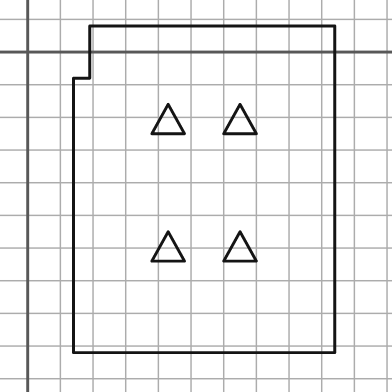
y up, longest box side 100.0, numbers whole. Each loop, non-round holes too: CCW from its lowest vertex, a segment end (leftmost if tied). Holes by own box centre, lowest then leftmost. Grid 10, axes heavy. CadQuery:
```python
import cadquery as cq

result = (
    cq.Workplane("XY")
    .moveTo(14.0, -92.0)
    .lineTo(94.0, -92.0)
    .lineTo(94.0, 8.0)
    .lineTo(19.0, 8.0)
    .lineTo(19.0, -8.0)
    .lineTo(14.0, -8.0)
    .close()
    .moveTo(38.0, -64.0)
    .lineTo(48.0, -64.0)
    .lineTo(43.0, -55.0)
    .close()
    .moveTo(60.0, -64.0)
    .lineTo(70.0, -64.0)
    .lineTo(65.0, -55.0)
    .close()
    .moveTo(38.0, -25.0)
    .lineTo(48.0, -25.0)
    .lineTo(43.0, -16.0)
    .close()
    .moveTo(60.0, -25.0)
    .lineTo(70.0, -25.0)
    .lineTo(65.0, -16.0)
    .close()
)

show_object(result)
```